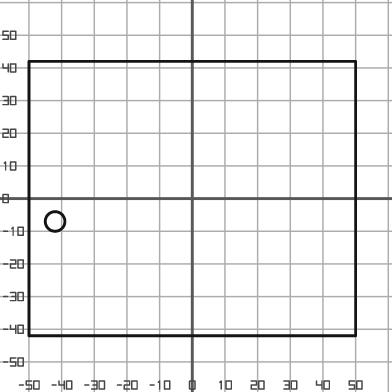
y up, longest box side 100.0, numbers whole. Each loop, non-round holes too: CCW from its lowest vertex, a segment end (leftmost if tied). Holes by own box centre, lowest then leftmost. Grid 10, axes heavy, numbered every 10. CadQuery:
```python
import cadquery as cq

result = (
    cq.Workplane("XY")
    .moveTo(-50.0, -42.0)
    .lineTo(50.0, -42.0)
    .lineTo(50.0, 42.0)
    .lineTo(-50.0, 42.0)
    .close()
    .moveTo(-42.0, -7.0)
    .circle(3.0)
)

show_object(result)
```